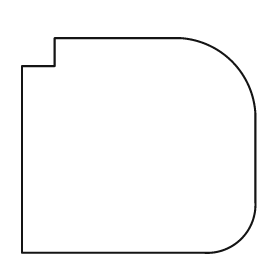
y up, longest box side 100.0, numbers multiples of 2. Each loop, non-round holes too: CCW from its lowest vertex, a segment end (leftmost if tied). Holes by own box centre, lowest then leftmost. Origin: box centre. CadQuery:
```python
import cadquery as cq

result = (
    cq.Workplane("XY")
    .moveTo(-50.0, -46.0)
    .lineTo(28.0, -46.0)
    .threePointArc((44.0, -40.0), (50.0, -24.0))
    .lineTo(50.0, 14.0)
    .threePointArc((40.0, 36.0), (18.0, 46.0))
    .lineTo(-36.0, 46.0)
    .lineTo(-36.0, 34.0)
    .lineTo(-50.0, 34.0)
    .close()
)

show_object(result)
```